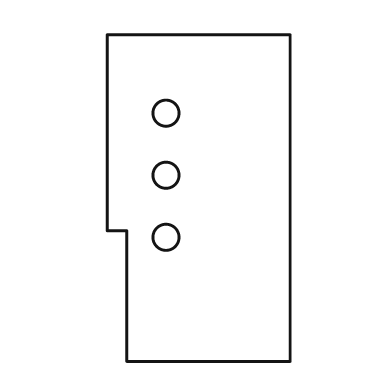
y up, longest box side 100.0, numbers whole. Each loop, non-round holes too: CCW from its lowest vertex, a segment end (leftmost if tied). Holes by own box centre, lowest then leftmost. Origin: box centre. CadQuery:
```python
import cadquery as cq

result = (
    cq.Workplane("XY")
    .moveTo(-22.0, -50.0)
    .lineTo(28.0, -50.0)
    .lineTo(28.0, 50.0)
    .lineTo(-28.0, 50.0)
    .lineTo(-28.0, -10.0)
    .lineTo(-22.0, -10.0)
    .close()
    .moveTo(-10.0, -12.0)
    .circle(4.0)
    .moveTo(-10.0, 7.0)
    .circle(4.0)
    .moveTo(-10.0, 26.0)
    .circle(4.0)
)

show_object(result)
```